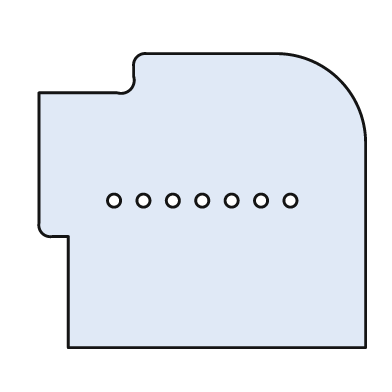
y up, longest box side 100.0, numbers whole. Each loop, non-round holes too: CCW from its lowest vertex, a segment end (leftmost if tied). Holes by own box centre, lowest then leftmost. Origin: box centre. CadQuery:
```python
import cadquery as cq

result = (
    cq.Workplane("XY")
    .moveTo(-41.0, -45.0)
    .lineTo(50.0, -45.0)
    .lineTo(50.0, 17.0)
    .threePointArc((42.0, 37.0), (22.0, 45.0))
    .lineTo(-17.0, 45.0)
    .threePointArc((-20.0, 44.0), (-21.0, 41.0))
    .lineTo(-21.0, 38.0)
    .threePointArc((-22.0, 34.0), (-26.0, 33.0))
    .lineTo(-50.0, 33.0)
    .lineTo(-50.0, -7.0)
    .threePointArc((-49.0, -10.0), (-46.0, -11.0))
    .lineTo(-41.0, -11.0)
    .close()
    .moveTo(-27.0, 0.0)
    .circle(2.0)
    .moveTo(-18.0, 0.0)
    .circle(2.0)
    .moveTo(-9.0, 0.0)
    .circle(2.0)
    .moveTo(0.0, 0.0)
    .circle(2.0)
    .moveTo(9.0, 0.0)
    .circle(2.0)
    .moveTo(18.0, 0.0)
    .circle(2.0)
    .moveTo(27.0, 0.0)
    .circle(2.0)
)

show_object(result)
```